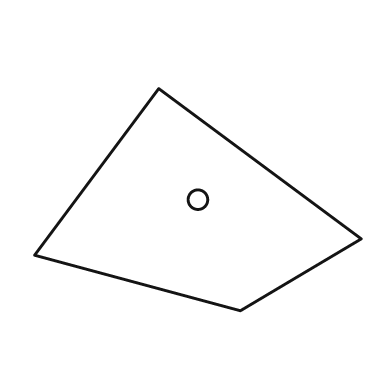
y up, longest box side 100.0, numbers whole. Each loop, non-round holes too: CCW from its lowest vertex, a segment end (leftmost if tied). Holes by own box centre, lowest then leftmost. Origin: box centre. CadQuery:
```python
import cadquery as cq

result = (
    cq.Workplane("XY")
    .moveTo(13.0, -34.0)
    .lineTo(50.0, -12.0)
    .lineTo(-12.0, 34.0)
    .lineTo(-50.0, -17.0)
    .close()
    .moveTo(0.0, 0.0)
    .circle(3.0)
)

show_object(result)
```